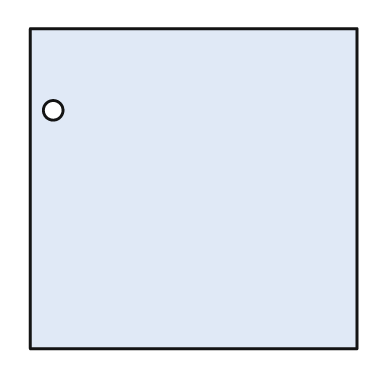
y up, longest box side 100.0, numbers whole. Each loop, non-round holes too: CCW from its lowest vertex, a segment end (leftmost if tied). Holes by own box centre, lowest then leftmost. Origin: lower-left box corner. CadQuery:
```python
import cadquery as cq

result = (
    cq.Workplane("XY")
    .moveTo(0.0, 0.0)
    .lineTo(100.0, 0.0)
    .lineTo(100.0, 98.0)
    .lineTo(0.0, 98.0)
    .close()
    .moveTo(7.0, 73.0)
    .circle(3.0)
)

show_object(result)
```